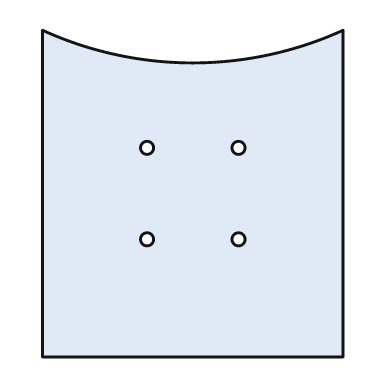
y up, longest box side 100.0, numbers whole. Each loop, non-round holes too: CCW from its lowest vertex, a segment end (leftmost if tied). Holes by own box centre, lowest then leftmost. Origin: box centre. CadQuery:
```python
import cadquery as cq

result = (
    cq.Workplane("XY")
    .moveTo(-46.0, -50.0)
    .lineTo(46.0, -50.0)
    .lineTo(46.0, 50.0)
    .threePointArc((0.0, 40.0), (-46.0, 50.0))
    .close()
    .moveTo(-14.0, -14.0)
    .circle(2.0)
    .moveTo(14.0, -14.0)
    .circle(2.0)
    .moveTo(-14.0, 14.0)
    .circle(2.0)
    .moveTo(14.0, 14.0)
    .circle(2.0)
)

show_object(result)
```